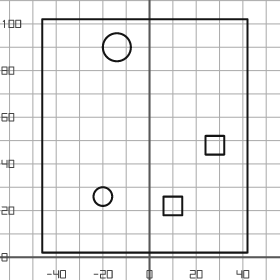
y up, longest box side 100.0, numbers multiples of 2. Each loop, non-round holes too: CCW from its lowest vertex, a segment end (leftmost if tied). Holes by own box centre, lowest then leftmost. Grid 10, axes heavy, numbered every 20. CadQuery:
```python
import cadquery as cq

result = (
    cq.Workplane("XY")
    .moveTo(-46.0, 2.0)
    .lineTo(42.0, 2.0)
    .lineTo(42.0, 102.0)
    .lineTo(-46.0, 102.0)
    .close()
    .moveTo(6.0, 18.0)
    .lineTo(14.0, 18.0)
    .lineTo(14.0, 26.0)
    .lineTo(6.0, 26.0)
    .close()
    .moveTo(-20.0, 26.0)
    .circle(4.0)
    .moveTo(24.0, 44.0)
    .lineTo(32.0, 44.0)
    .lineTo(32.0, 52.0)
    .lineTo(24.0, 52.0)
    .close()
    .moveTo(-14.0, 90.0)
    .circle(6.0)
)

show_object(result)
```